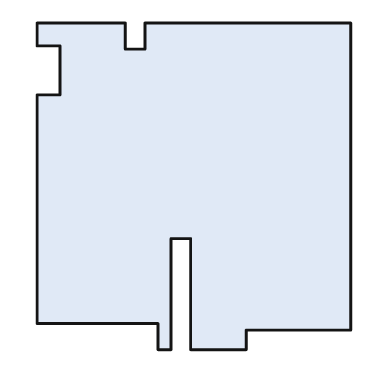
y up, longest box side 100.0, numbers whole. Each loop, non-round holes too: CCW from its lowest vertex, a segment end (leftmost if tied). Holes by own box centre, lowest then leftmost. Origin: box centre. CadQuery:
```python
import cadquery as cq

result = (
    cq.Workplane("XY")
    .moveTo(-11.0, -50.0)
    .lineTo(-7.0, -50.0)
    .lineTo(-7.0, -16.0)
    .lineTo(-1.0, -16.0)
    .lineTo(-1.0, -50.0)
    .lineTo(16.0, -50.0)
    .lineTo(16.0, -44.0)
    .lineTo(48.0, -44.0)
    .lineTo(48.0, 50.0)
    .lineTo(-15.0, 50.0)
    .lineTo(-15.0, 42.0)
    .lineTo(-21.0, 42.0)
    .lineTo(-21.0, 50.0)
    .lineTo(-48.0, 50.0)
    .lineTo(-48.0, 43.0)
    .lineTo(-41.0, 43.0)
    .lineTo(-41.0, 28.0)
    .lineTo(-48.0, 28.0)
    .lineTo(-48.0, -42.0)
    .lineTo(-11.0, -42.0)
    .close()
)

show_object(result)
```